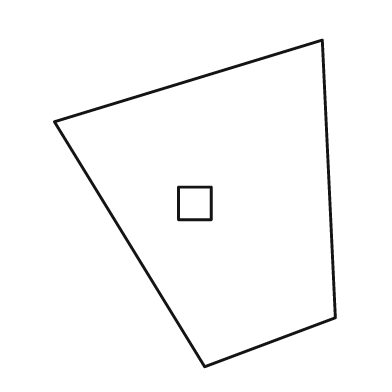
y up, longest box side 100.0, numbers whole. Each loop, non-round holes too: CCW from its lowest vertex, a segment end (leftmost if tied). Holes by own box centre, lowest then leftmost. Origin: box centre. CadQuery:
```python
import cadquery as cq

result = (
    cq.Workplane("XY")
    .moveTo(3.0, -50.0)
    .lineTo(43.0, -35.0)
    .lineTo(39.0, 50.0)
    .lineTo(-43.0, 25.0)
    .close()
    .moveTo(-5.0, -5.0)
    .lineTo(5.0, -5.0)
    .lineTo(5.0, 5.0)
    .lineTo(-5.0, 5.0)
    .close()
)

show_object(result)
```